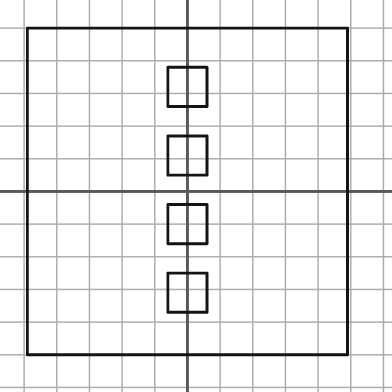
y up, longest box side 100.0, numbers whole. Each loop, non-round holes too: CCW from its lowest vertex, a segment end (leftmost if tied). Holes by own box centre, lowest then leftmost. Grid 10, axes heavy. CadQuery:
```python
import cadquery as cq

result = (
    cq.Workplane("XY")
    .moveTo(-49.0, -50.0)
    .lineTo(49.0, -50.0)
    .lineTo(49.0, 50.0)
    .lineTo(-49.0, 50.0)
    .close()
    .moveTo(-6.0, -37.0)
    .lineTo(6.0, -37.0)
    .lineTo(6.0, -25.0)
    .lineTo(-6.0, -25.0)
    .close()
    .moveTo(-6.0, -16.0)
    .lineTo(6.0, -16.0)
    .lineTo(6.0, -4.0)
    .lineTo(-6.0, -4.0)
    .close()
    .moveTo(-6.0, 5.0)
    .lineTo(6.0, 5.0)
    .lineTo(6.0, 17.0)
    .lineTo(-6.0, 17.0)
    .close()
    .moveTo(-6.0, 26.0)
    .lineTo(6.0, 26.0)
    .lineTo(6.0, 38.0)
    .lineTo(-6.0, 38.0)
    .close()
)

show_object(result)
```